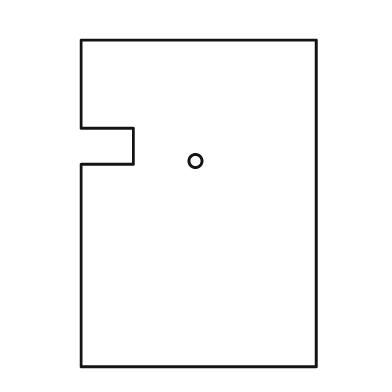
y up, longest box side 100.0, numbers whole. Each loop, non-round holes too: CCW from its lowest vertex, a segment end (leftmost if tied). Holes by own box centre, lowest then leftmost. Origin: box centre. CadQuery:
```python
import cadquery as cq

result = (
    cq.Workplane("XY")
    .moveTo(-36.0, -50.0)
    .lineTo(36.0, -50.0)
    .lineTo(36.0, 50.0)
    .lineTo(-36.0, 50.0)
    .lineTo(-36.0, 23.0)
    .lineTo(-20.0, 23.0)
    .lineTo(-20.0, 12.0)
    .lineTo(-36.0, 12.0)
    .close()
    .moveTo(-1.0, 13.0)
    .circle(2.0)
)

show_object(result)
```